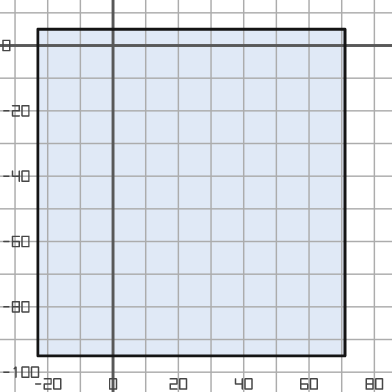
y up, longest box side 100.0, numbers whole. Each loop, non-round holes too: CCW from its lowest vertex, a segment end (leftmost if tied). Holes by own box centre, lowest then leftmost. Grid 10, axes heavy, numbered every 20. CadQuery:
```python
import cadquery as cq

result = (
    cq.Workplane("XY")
    .moveTo(-23.0, -95.0)
    .lineTo(71.0, -95.0)
    .lineTo(71.0, 5.0)
    .lineTo(-23.0, 5.0)
    .close()
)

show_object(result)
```